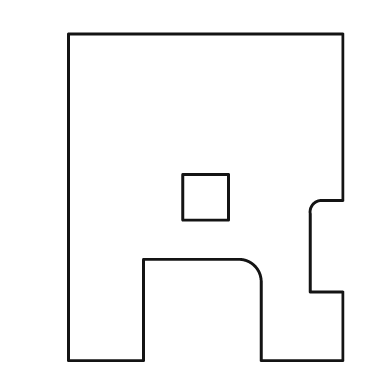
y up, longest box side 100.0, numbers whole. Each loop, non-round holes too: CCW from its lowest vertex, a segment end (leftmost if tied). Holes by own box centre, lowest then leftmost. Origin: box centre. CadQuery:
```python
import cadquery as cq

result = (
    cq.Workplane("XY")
    .moveTo(-42.0, -50.0)
    .lineTo(-19.0, -50.0)
    .lineTo(-19.0, -19.0)
    .lineTo(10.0, -19.0)
    .threePointArc((15.0, -21.0), (17.0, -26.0))
    .lineTo(17.0, -50.0)
    .lineTo(42.0, -50.0)
    .lineTo(42.0, -29.0)
    .lineTo(32.0, -29.0)
    .lineTo(32.0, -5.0)
    .threePointArc((33.0, -2.0), (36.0, -1.0))
    .lineTo(42.0, -1.0)
    .lineTo(42.0, 50.0)
    .lineTo(-42.0, 50.0)
    .close()
    .moveTo(-7.0, -7.0)
    .lineTo(7.0, -7.0)
    .lineTo(7.0, 7.0)
    .lineTo(-7.0, 7.0)
    .close()
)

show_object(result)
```